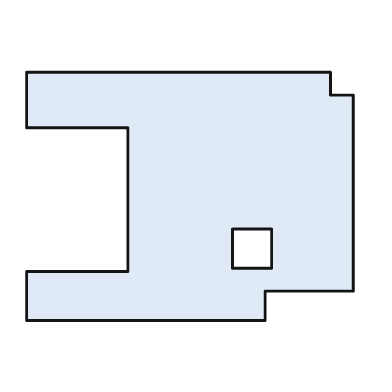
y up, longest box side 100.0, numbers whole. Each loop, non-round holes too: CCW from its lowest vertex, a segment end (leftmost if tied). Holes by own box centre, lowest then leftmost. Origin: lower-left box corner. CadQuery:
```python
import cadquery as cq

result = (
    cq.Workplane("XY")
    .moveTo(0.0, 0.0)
    .lineTo(73.0, 0.0)
    .lineTo(73.0, 9.0)
    .lineTo(100.0, 9.0)
    .lineTo(100.0, 69.0)
    .lineTo(93.0, 69.0)
    .lineTo(93.0, 76.0)
    .lineTo(0.0, 76.0)
    .lineTo(0.0, 59.0)
    .lineTo(31.0, 59.0)
    .lineTo(31.0, 15.0)
    .lineTo(0.0, 15.0)
    .close()
    .moveTo(63.0, 16.0)
    .lineTo(75.0, 16.0)
    .lineTo(75.0, 28.0)
    .lineTo(63.0, 28.0)
    .close()
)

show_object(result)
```